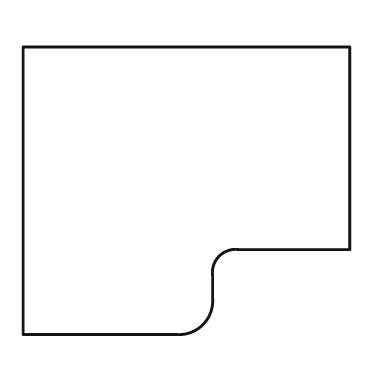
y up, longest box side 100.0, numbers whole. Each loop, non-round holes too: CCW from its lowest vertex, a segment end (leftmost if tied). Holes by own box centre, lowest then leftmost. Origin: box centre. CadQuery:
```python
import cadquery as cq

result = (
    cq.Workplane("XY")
    .moveTo(-50.0, -44.0)
    .lineTo(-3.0, -44.0)
    .threePointArc((5.0, -41.0), (8.0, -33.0))
    .lineTo(8.0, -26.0)
    .threePointArc((10.0, -20.0), (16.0, -18.0))
    .lineTo(50.0, -18.0)
    .lineTo(50.0, 44.0)
    .lineTo(-50.0, 44.0)
    .close()
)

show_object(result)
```